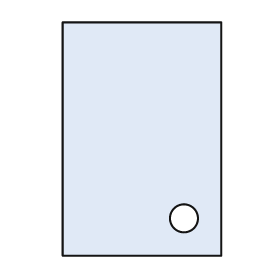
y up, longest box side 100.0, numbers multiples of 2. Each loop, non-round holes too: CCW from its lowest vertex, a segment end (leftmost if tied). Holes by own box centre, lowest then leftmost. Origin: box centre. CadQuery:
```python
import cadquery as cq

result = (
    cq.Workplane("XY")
    .moveTo(-34.0, -50.0)
    .lineTo(34.0, -50.0)
    .lineTo(34.0, 50.0)
    .lineTo(-34.0, 50.0)
    .close()
    .moveTo(18.0, -34.0)
    .circle(6.0)
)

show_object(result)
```